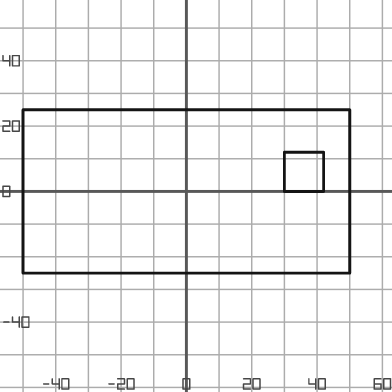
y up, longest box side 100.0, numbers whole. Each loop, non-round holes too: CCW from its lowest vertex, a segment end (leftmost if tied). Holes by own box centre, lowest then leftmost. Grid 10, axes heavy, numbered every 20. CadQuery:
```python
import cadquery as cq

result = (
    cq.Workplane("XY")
    .moveTo(-50.0, -25.0)
    .lineTo(50.0, -25.0)
    .lineTo(50.0, 25.0)
    .lineTo(-50.0, 25.0)
    .close()
    .moveTo(30.0, 0.0)
    .lineTo(42.0, 0.0)
    .lineTo(42.0, 12.0)
    .lineTo(30.0, 12.0)
    .close()
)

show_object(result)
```